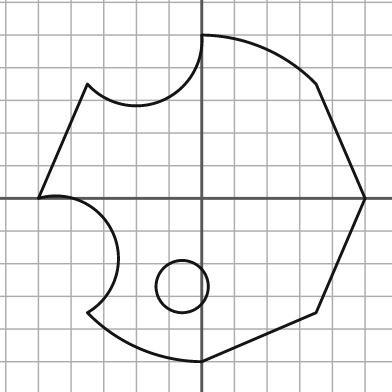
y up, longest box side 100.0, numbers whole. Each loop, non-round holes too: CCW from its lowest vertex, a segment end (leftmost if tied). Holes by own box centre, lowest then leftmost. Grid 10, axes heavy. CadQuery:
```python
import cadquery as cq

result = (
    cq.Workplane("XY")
    .moveTo(0.0, -50.0)
    .lineTo(35.0, -35.0)
    .lineTo(50.0, 0.0)
    .lineTo(35.0, 35.0)
    .threePointArc((19.0, 46.0), (0.0, 50.0))
    .threePointArc((-12.0, 30.0), (-35.0, 35.0))
    .lineTo(-50.0, 0.0)
    .threePointArc((-27.0, -11.0), (-35.0, -35.0))
    .threePointArc((-19.0, -46.0), (0.0, -50.0))
    .close()
    .moveTo(-6.0, -27.0)
    .circle(8.0)
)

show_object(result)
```